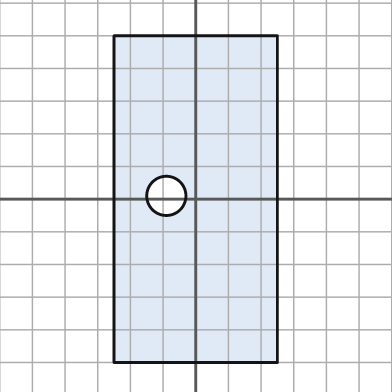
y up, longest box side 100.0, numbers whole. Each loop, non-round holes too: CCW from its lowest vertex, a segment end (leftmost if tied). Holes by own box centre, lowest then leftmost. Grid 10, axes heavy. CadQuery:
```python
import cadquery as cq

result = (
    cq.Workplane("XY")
    .moveTo(-25.0, -50.0)
    .lineTo(25.0, -50.0)
    .lineTo(25.0, 50.0)
    .lineTo(-25.0, 50.0)
    .close()
    .moveTo(-9.0, 1.0)
    .circle(6.0)
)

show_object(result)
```